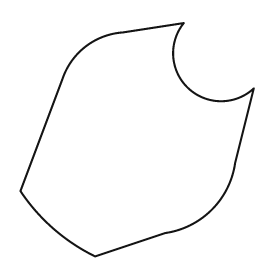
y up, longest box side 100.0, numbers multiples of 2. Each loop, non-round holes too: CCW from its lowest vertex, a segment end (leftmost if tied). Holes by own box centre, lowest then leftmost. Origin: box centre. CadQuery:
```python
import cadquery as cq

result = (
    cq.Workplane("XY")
    .moveTo(-18.0, -50.0)
    .lineTo(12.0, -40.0)
    .threePointArc((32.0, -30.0), (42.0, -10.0))
    .lineTo(50.0, 22.0)
    .threePointArc((22.0, 22.0), (20.0, 50.0))
    .lineTo(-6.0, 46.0)
    .threePointArc((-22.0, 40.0), (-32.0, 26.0))
    .lineTo(-50.0, -22.0)
    .threePointArc((-36.0, -38.0), (-18.0, -50.0))
    .close()
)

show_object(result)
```